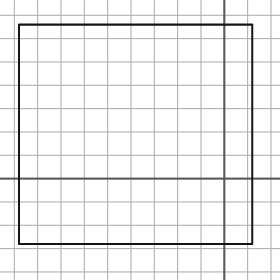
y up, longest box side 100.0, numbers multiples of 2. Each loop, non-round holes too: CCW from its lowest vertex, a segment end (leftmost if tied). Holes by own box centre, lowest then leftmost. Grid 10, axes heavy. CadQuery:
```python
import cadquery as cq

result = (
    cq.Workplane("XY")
    .moveTo(-88.0, -28.0)
    .lineTo(12.0, -28.0)
    .lineTo(12.0, 66.0)
    .lineTo(-88.0, 66.0)
    .close()
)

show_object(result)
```